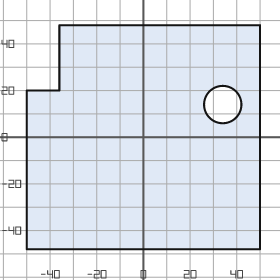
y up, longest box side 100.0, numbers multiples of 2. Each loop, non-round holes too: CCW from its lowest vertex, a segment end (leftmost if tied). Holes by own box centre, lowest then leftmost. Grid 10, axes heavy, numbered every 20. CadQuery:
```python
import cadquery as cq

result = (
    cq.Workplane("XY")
    .moveTo(-50.0, -48.0)
    .lineTo(50.0, -48.0)
    .lineTo(50.0, 48.0)
    .lineTo(-36.0, 48.0)
    .lineTo(-36.0, 20.0)
    .lineTo(-50.0, 20.0)
    .close()
    .moveTo(34.0, 14.0)
    .circle(8.0)
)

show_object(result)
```